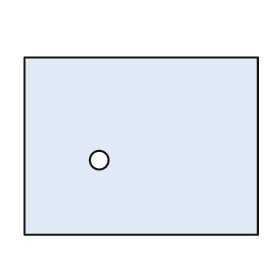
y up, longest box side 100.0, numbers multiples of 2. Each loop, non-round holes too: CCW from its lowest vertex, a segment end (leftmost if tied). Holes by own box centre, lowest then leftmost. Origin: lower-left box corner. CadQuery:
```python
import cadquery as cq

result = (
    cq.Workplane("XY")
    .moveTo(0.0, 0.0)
    .lineTo(100.0, 0.0)
    .lineTo(100.0, 76.0)
    .lineTo(0.0, 76.0)
    .close()
    .moveTo(32.0, 32.0)
    .circle(4.0)
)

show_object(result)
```